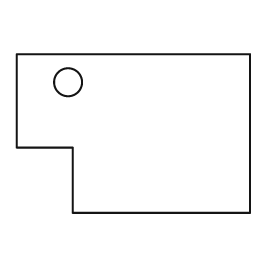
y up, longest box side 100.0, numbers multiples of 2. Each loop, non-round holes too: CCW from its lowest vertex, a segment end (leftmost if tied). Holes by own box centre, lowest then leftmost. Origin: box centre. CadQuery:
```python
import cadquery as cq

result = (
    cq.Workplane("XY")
    .moveTo(-26.0, -34.0)
    .lineTo(50.0, -34.0)
    .lineTo(50.0, 34.0)
    .lineTo(-50.0, 34.0)
    .lineTo(-50.0, -6.0)
    .lineTo(-26.0, -6.0)
    .close()
    .moveTo(-28.0, 22.0)
    .circle(6.0)
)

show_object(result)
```